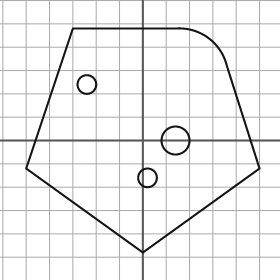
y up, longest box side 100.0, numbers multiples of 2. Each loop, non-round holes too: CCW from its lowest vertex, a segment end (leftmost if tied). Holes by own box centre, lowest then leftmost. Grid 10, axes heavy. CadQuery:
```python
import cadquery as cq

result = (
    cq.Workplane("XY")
    .moveTo(0.0, -48.0)
    .lineTo(50.0, -12.0)
    .lineTo(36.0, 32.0)
    .threePointArc((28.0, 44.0), (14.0, 48.0))
    .lineTo(-30.0, 48.0)
    .lineTo(-50.0, -12.0)
    .close()
    .moveTo(2.0, -16.0)
    .circle(4.0)
    .moveTo(14.0, 0.0)
    .circle(6.0)
    .moveTo(-24.0, 24.0)
    .circle(4.0)
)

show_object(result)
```